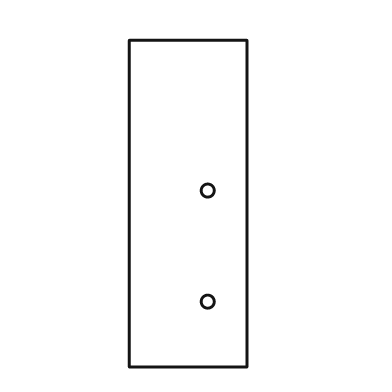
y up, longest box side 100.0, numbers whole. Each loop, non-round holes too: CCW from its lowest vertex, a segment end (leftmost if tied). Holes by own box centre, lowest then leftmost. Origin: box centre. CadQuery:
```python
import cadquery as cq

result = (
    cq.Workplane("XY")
    .moveTo(-18.0, -50.0)
    .lineTo(18.0, -50.0)
    .lineTo(18.0, 50.0)
    .lineTo(-18.0, 50.0)
    .close()
    .moveTo(6.0, -30.0)
    .circle(2.0)
    .moveTo(6.0, 4.0)
    .circle(2.0)
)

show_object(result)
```